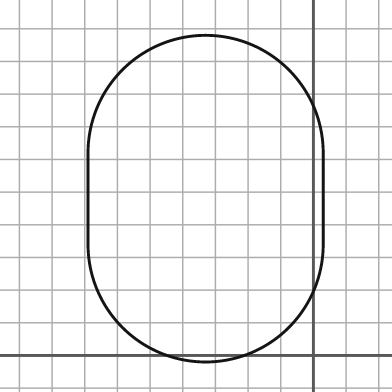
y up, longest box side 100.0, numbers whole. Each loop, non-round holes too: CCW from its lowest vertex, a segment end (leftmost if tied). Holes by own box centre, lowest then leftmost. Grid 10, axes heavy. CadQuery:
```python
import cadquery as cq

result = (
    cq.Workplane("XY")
    .moveTo(-69.0, 34.0)
    .threePointArc((-33.0, -2.0), (3.0, 34.0))
    .lineTo(3.0, 62.0)
    .threePointArc((-33.0, 98.0), (-69.0, 62.0))
    .close()
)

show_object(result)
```